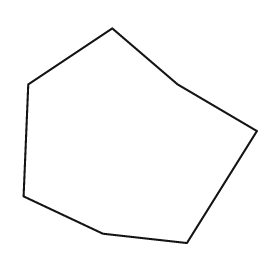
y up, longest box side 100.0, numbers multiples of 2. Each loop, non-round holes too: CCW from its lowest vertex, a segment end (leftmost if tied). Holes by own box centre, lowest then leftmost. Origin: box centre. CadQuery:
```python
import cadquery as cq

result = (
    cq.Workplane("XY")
    .moveTo(20.0, -46.0)
    .lineTo(50.0, 2.0)
    .lineTo(16.0, 22.0)
    .lineTo(-12.0, 46.0)
    .lineTo(-48.0, 22.0)
    .lineTo(-50.0, -26.0)
    .lineTo(-16.0, -42.0)
    .close()
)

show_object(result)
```